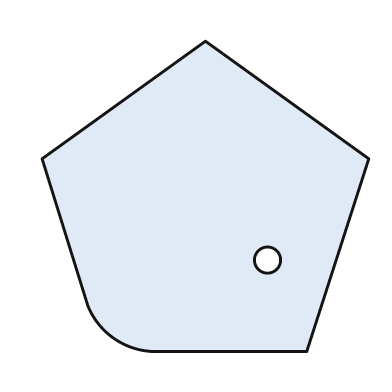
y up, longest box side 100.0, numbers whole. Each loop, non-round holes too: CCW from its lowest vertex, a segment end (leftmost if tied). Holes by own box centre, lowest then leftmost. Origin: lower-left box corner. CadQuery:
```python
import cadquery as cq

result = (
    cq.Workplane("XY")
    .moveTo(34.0, 0.0)
    .lineTo(81.0, 0.0)
    .lineTo(100.0, 59.0)
    .lineTo(50.0, 95.0)
    .lineTo(0.0, 59.0)
    .lineTo(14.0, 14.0)
    .threePointArc((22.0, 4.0), (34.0, 0.0))
    .close()
    .moveTo(69.0, 28.0)
    .circle(4.0)
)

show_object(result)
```